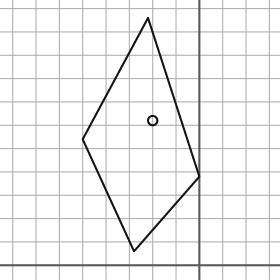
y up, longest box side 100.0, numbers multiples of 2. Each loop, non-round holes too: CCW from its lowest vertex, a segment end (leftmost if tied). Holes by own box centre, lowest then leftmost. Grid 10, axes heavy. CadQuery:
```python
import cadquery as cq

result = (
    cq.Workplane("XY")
    .moveTo(-28.0, 6.0)
    .lineTo(0.0, 38.0)
    .lineTo(-22.0, 106.0)
    .lineTo(-50.0, 54.0)
    .close()
    .moveTo(-20.0, 62.0)
    .circle(2.0)
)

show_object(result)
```